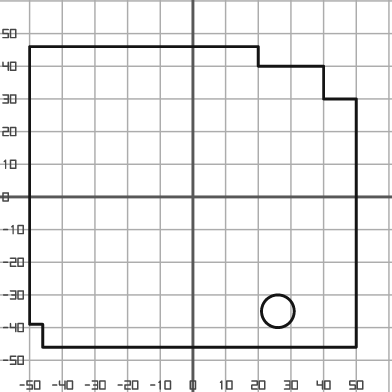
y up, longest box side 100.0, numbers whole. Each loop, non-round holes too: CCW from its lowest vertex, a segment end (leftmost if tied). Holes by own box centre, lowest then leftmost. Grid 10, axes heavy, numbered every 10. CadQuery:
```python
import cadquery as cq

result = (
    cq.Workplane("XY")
    .moveTo(-46.0, -46.0)
    .lineTo(50.0, -46.0)
    .lineTo(50.0, 30.0)
    .lineTo(40.0, 30.0)
    .lineTo(40.0, 40.0)
    .lineTo(20.0, 40.0)
    .lineTo(20.0, 46.0)
    .lineTo(-50.0, 46.0)
    .lineTo(-50.0, -39.0)
    .lineTo(-46.0, -39.0)
    .close()
    .moveTo(26.0, -35.0)
    .circle(5.0)
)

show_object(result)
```